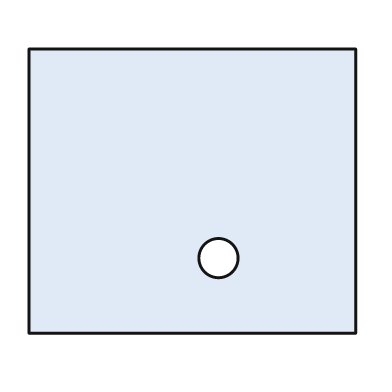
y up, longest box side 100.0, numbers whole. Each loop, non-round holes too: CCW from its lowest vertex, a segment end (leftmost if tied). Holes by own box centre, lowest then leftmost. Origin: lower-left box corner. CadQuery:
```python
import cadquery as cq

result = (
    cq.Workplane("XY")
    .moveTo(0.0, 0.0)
    .lineTo(100.0, 0.0)
    .lineTo(100.0, 87.0)
    .lineTo(0.0, 87.0)
    .close()
    .moveTo(58.0, 23.0)
    .circle(6.0)
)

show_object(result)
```